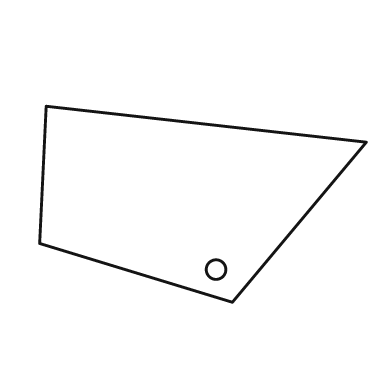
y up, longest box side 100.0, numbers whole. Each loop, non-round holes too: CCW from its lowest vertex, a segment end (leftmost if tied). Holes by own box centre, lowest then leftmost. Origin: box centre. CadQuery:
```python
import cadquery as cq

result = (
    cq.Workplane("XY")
    .moveTo(9.0, -30.0)
    .lineTo(50.0, 19.0)
    .lineTo(-48.0, 30.0)
    .lineTo(-50.0, -12.0)
    .close()
    .moveTo(4.0, -20.0)
    .circle(3.0)
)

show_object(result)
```